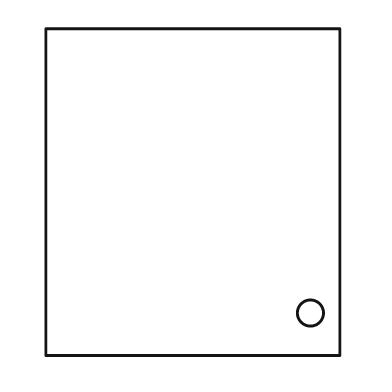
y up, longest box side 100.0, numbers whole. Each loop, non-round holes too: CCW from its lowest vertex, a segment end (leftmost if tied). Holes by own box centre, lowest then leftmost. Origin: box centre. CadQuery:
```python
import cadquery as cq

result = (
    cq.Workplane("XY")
    .moveTo(-45.0, -50.0)
    .lineTo(45.0, -50.0)
    .lineTo(45.0, 50.0)
    .lineTo(-45.0, 50.0)
    .close()
    .moveTo(36.0, -37.0)
    .circle(4.0)
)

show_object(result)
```